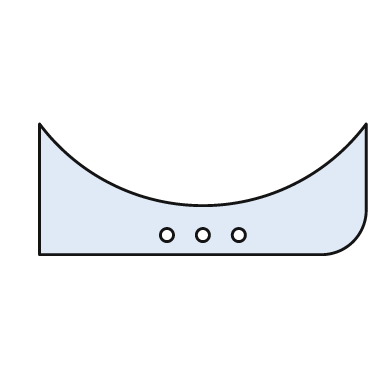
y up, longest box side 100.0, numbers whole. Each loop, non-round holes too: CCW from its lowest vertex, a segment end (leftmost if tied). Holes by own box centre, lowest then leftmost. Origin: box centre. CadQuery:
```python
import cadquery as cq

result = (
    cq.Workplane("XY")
    .moveTo(-50.0, -20.0)
    .lineTo(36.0, -20.0)
    .threePointArc((46.0, -16.0), (50.0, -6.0))
    .lineTo(50.0, 20.0)
    .threePointArc((0.0, -5.0), (-50.0, 20.0))
    .close()
    .moveTo(-11.0, -14.0)
    .circle(2.0)
    .moveTo(0.0, -14.0)
    .circle(2.0)
    .moveTo(11.0, -14.0)
    .circle(2.0)
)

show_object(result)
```